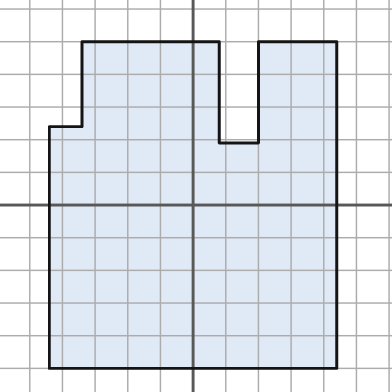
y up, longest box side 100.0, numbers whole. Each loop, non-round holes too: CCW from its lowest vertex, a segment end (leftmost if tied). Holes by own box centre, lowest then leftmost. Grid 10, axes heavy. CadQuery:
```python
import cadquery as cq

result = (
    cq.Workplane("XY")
    .moveTo(-44.0, -50.0)
    .lineTo(44.0, -50.0)
    .lineTo(44.0, 50.0)
    .lineTo(20.0, 50.0)
    .lineTo(20.0, 19.0)
    .lineTo(8.0, 19.0)
    .lineTo(8.0, 50.0)
    .lineTo(-34.0, 50.0)
    .lineTo(-34.0, 24.0)
    .lineTo(-44.0, 24.0)
    .close()
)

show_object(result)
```